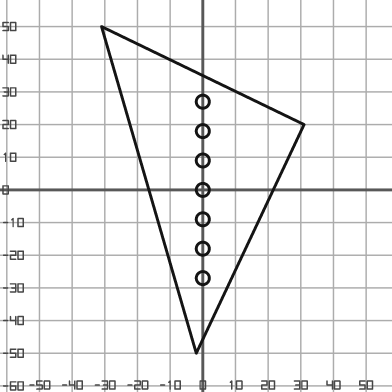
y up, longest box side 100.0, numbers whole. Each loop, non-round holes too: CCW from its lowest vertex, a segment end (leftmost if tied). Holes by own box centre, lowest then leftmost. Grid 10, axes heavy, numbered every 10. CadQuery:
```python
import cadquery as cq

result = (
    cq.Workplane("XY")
    .moveTo(-2.0, -50.0)
    .lineTo(31.0, 20.0)
    .lineTo(-31.0, 50.0)
    .close()
    .moveTo(0.0, -27.0)
    .circle(2.0)
    .moveTo(0.0, -18.0)
    .circle(2.0)
    .moveTo(0.0, -9.0)
    .circle(2.0)
    .moveTo(0.0, 0.0)
    .circle(2.0)
    .moveTo(0.0, 9.0)
    .circle(2.0)
    .moveTo(0.0, 18.0)
    .circle(2.0)
    .moveTo(0.0, 27.0)
    .circle(2.0)
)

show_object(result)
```